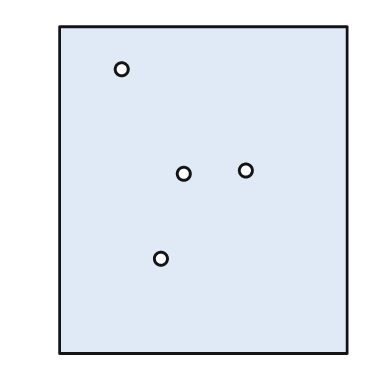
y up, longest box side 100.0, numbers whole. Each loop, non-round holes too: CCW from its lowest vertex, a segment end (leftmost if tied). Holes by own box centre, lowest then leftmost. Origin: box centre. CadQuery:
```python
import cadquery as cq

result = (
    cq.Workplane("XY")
    .moveTo(-44.0, -50.0)
    .lineTo(44.0, -50.0)
    .lineTo(44.0, 50.0)
    .lineTo(-44.0, 50.0)
    .close()
    .moveTo(-13.0, -21.0)
    .circle(2.0)
    .moveTo(-6.0, 5.0)
    .circle(2.0)
    .moveTo(13.0, 6.0)
    .circle(2.0)
    .moveTo(-25.0, 37.0)
    .circle(2.0)
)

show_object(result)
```